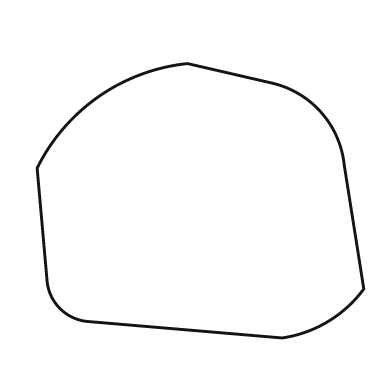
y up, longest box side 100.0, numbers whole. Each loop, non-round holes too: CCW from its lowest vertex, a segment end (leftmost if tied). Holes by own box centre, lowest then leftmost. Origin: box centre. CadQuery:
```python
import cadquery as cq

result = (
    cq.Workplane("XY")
    .moveTo(25.0, -42.0)
    .threePointArc((39.0, -37.0), (50.0, -27.0))
    .lineTo(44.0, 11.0)
    .threePointArc((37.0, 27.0), (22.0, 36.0))
    .lineTo(-4.0, 42.0)
    .threePointArc((-31.0, 32.0), (-50.0, 10.0))
    .lineTo(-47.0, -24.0)
    .threePointArc((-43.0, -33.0), (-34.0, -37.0))
    .close()
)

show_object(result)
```